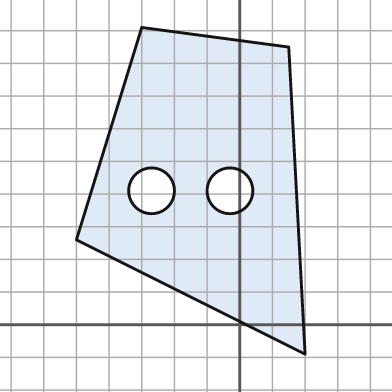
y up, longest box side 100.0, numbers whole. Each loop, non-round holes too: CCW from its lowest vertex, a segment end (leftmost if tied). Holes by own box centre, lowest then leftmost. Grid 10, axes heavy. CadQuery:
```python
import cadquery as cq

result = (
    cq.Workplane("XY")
    .moveTo(20.0, -9.0)
    .lineTo(15.0, 85.0)
    .lineTo(-30.0, 91.0)
    .lineTo(-50.0, 26.0)
    .close()
    .moveTo(-27.0, 41.0)
    .circle(7.0)
    .moveTo(-3.0, 41.0)
    .circle(7.0)
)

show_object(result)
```